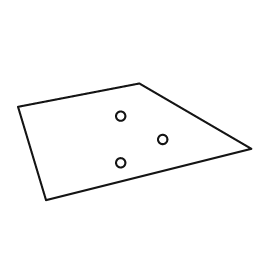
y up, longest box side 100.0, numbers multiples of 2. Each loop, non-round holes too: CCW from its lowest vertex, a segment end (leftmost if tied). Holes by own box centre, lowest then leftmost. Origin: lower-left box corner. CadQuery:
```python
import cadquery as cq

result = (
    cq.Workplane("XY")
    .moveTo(12.0, 0.0)
    .lineTo(100.0, 22.0)
    .lineTo(52.0, 50.0)
    .lineTo(0.0, 40.0)
    .close()
    .moveTo(44.0, 16.0)
    .circle(2.0)
    .moveTo(62.0, 26.0)
    .circle(2.0)
    .moveTo(44.0, 36.0)
    .circle(2.0)
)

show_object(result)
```